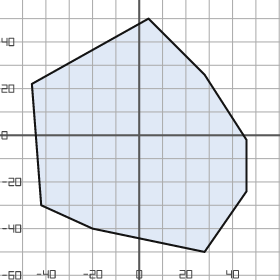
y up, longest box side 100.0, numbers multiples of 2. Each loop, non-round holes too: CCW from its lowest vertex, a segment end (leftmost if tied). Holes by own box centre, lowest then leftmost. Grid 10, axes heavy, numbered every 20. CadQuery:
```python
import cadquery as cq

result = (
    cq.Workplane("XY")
    .moveTo(28.0, -50.0)
    .lineTo(46.0, -24.0)
    .lineTo(46.0, -2.0)
    .lineTo(28.0, 26.0)
    .lineTo(4.0, 50.0)
    .lineTo(-46.0, 22.0)
    .lineTo(-42.0, -30.0)
    .lineTo(-20.0, -40.0)
    .close()
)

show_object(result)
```